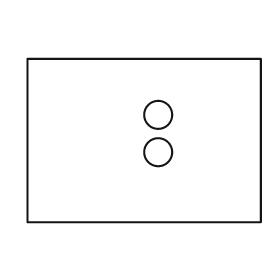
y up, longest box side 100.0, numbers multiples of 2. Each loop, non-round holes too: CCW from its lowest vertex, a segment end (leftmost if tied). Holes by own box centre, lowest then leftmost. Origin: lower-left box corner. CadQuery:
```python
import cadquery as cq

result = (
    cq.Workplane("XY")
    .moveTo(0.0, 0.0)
    .lineTo(100.0, 0.0)
    .lineTo(100.0, 70.0)
    .lineTo(0.0, 70.0)
    .close()
    .moveTo(56.0, 30.0)
    .circle(6.0)
    .moveTo(56.0, 46.0)
    .circle(6.0)
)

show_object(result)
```